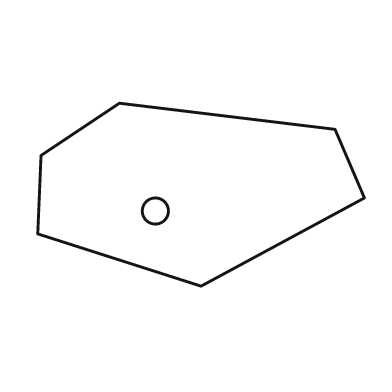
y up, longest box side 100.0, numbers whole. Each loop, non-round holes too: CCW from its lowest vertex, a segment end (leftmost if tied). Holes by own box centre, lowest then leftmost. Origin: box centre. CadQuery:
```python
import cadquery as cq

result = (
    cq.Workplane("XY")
    .moveTo(0.0, -28.0)
    .lineTo(50.0, -1.0)
    .lineTo(41.0, 20.0)
    .lineTo(-25.0, 28.0)
    .lineTo(-49.0, 12.0)
    .lineTo(-50.0, -12.0)
    .close()
    .moveTo(-14.0, -5.0)
    .circle(4.0)
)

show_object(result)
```